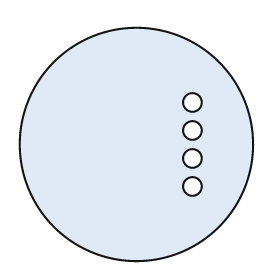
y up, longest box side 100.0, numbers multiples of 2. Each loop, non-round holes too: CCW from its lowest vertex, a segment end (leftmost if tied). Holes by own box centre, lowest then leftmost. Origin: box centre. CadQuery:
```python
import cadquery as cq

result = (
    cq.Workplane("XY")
    .moveTo(0.0, 0.0)
    .circle(50.0)
    .moveTo(24.0, -18.0)
    .circle(4.0)
    .moveTo(24.0, -6.0)
    .circle(4.0)
    .moveTo(24.0, 6.0)
    .circle(4.0)
    .moveTo(24.0, 18.0)
    .circle(4.0)
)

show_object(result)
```